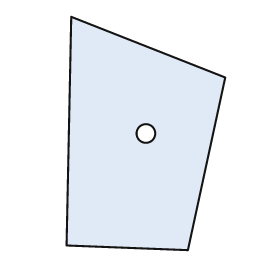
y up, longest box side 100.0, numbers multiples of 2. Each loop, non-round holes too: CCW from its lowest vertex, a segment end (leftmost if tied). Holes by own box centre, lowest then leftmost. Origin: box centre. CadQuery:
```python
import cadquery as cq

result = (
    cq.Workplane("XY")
    .moveTo(18.0, -50.0)
    .lineTo(34.0, 24.0)
    .lineTo(-32.0, 50.0)
    .lineTo(-34.0, -48.0)
    .close()
    .moveTo(0.0, 0.0)
    .circle(4.0)
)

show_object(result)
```